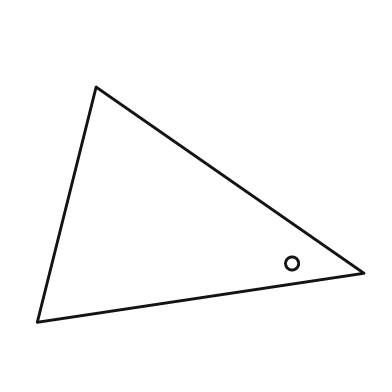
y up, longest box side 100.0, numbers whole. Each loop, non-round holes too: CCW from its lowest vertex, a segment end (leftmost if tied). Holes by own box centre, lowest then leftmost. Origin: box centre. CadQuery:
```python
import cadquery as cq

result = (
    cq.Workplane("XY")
    .moveTo(-50.0, -36.0)
    .lineTo(50.0, -21.0)
    .lineTo(-32.0, 36.0)
    .close()
    .moveTo(28.0, -18.0)
    .circle(2.0)
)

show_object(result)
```